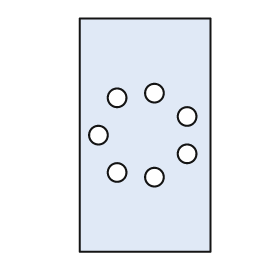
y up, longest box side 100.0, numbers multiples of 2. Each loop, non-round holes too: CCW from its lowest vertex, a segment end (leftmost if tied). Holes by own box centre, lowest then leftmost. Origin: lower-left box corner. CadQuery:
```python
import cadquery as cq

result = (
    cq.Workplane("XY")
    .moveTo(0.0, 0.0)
    .lineTo(56.0, 0.0)
    .lineTo(56.0, 100.0)
    .lineTo(0.0, 100.0)
    .close()
    .moveTo(32.0, 32.0)
    .circle(4.0)
    .moveTo(16.0, 34.0)
    .circle(4.0)
    .moveTo(46.0, 42.0)
    .circle(4.0)
    .moveTo(8.0, 50.0)
    .circle(4.0)
    .moveTo(46.0, 58.0)
    .circle(4.0)
    .moveTo(16.0, 66.0)
    .circle(4.0)
    .moveTo(32.0, 68.0)
    .circle(4.0)
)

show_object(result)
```